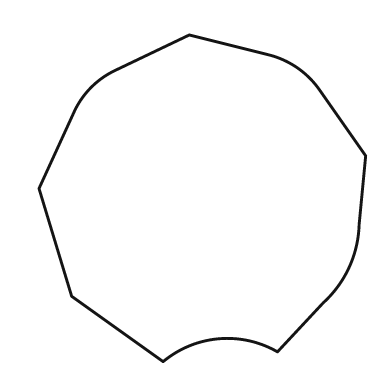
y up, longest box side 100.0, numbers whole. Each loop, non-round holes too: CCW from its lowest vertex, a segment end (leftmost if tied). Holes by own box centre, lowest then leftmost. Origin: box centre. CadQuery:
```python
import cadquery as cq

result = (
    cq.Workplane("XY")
    .moveTo(-12.0, -50.0)
    .threePointArc((5.0, -43.0), (23.0, -47.0))
    .lineTo(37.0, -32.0)
    .threePointArc((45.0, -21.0), (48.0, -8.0))
    .lineTo(50.0, 13.0)
    .lineTo(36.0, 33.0)
    .threePointArc((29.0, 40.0), (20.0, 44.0))
    .lineTo(-4.0, 50.0)
    .lineTo(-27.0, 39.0)
    .threePointArc((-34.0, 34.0), (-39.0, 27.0))
    .lineTo(-50.0, 3.0)
    .lineTo(-40.0, -30.0)
    .close()
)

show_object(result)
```